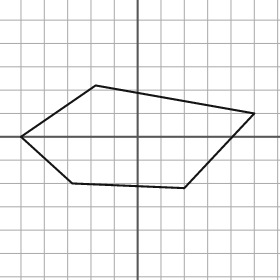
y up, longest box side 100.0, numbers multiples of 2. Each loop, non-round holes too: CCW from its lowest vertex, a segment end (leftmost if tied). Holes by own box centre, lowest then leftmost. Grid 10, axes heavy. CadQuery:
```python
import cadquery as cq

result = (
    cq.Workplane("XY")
    .moveTo(20.0, -22.0)
    .lineTo(50.0, 10.0)
    .lineTo(-18.0, 22.0)
    .lineTo(-50.0, 0.0)
    .lineTo(-28.0, -20.0)
    .close()
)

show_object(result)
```